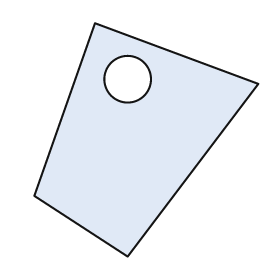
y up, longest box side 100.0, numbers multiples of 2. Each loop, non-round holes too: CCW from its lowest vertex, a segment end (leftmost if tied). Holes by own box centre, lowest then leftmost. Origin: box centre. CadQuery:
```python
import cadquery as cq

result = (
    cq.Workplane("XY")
    .moveTo(-8.0, -50.0)
    .lineTo(48.0, 24.0)
    .lineTo(-22.0, 50.0)
    .lineTo(-48.0, -24.0)
    .close()
    .moveTo(-8.0, 26.0)
    .circle(10.0)
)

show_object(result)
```